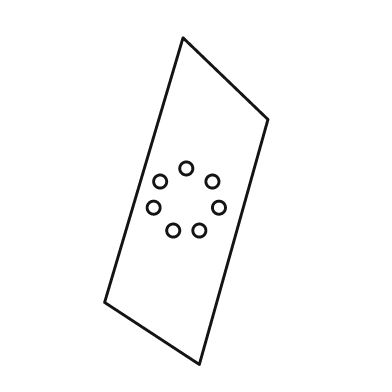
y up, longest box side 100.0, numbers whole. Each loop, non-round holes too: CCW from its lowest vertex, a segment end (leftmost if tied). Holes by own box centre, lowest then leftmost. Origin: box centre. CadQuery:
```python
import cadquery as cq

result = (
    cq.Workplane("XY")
    .moveTo(4.0, -50.0)
    .lineTo(25.0, 25.0)
    .lineTo(-1.0, 50.0)
    .lineTo(-25.0, -31.0)
    .close()
    .moveTo(-4.0, -9.0)
    .circle(2.0)
    .moveTo(4.0, -9.0)
    .circle(2.0)
    .moveTo(-10.0, -2.0)
    .circle(2.0)
    .moveTo(10.0, -2.0)
    .circle(2.0)
    .moveTo(-8.0, 6.0)
    .circle(2.0)
    .moveTo(8.0, 6.0)
    .circle(2.0)
    .moveTo(0.0, 10.0)
    .circle(2.0)
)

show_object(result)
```